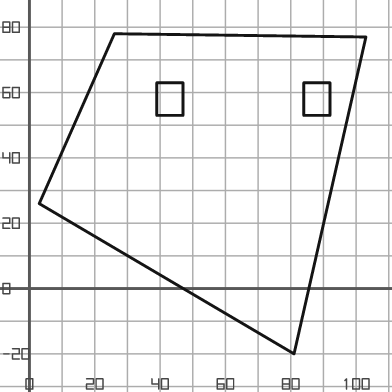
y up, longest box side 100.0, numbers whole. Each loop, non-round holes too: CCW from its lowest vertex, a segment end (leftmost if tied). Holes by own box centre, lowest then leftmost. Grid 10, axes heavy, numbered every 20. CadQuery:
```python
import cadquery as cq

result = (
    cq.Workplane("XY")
    .moveTo(81.0, -20.0)
    .lineTo(103.0, 77.0)
    .lineTo(26.0, 78.0)
    .lineTo(3.0, 26.0)
    .close()
    .moveTo(39.0, 53.0)
    .lineTo(47.0, 53.0)
    .lineTo(47.0, 63.0)
    .lineTo(39.0, 63.0)
    .close()
    .moveTo(84.0, 53.0)
    .lineTo(92.0, 53.0)
    .lineTo(92.0, 63.0)
    .lineTo(84.0, 63.0)
    .close()
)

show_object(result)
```